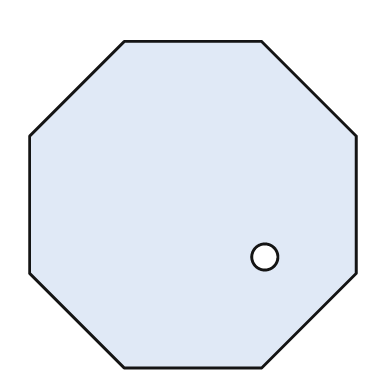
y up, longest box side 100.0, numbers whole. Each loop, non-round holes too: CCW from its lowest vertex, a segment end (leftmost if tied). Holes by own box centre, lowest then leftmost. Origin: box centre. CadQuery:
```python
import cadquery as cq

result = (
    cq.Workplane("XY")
    .moveTo(-21.0, -50.0)
    .lineTo(21.0, -50.0)
    .lineTo(50.0, -21.0)
    .lineTo(50.0, 21.0)
    .lineTo(21.0, 50.0)
    .lineTo(-21.0, 50.0)
    .lineTo(-50.0, 21.0)
    .lineTo(-50.0, -21.0)
    .close()
    .moveTo(22.0, -16.0)
    .circle(4.0)
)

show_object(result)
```